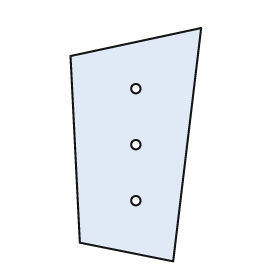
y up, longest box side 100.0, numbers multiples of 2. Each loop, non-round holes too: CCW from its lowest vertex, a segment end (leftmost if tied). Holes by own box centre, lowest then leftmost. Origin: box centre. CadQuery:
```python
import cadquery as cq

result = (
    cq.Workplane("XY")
    .moveTo(16.0, -50.0)
    .lineTo(28.0, 50.0)
    .lineTo(-28.0, 38.0)
    .lineTo(-24.0, -42.0)
    .close()
    .moveTo(0.0, -24.0)
    .circle(2.0)
    .moveTo(0.0, 0.0)
    .circle(2.0)
    .moveTo(0.0, 24.0)
    .circle(2.0)
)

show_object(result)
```